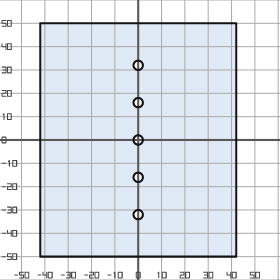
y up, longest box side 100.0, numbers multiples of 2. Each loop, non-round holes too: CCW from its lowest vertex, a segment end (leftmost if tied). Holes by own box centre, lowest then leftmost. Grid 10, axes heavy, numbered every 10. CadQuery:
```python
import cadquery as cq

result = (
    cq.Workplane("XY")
    .moveTo(-42.0, -50.0)
    .lineTo(42.0, -50.0)
    .lineTo(42.0, 50.0)
    .lineTo(-42.0, 50.0)
    .close()
    .moveTo(0.0, -32.0)
    .circle(2.0)
    .moveTo(0.0, -16.0)
    .circle(2.0)
    .moveTo(0.0, 0.0)
    .circle(2.0)
    .moveTo(0.0, 16.0)
    .circle(2.0)
    .moveTo(0.0, 32.0)
    .circle(2.0)
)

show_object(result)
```